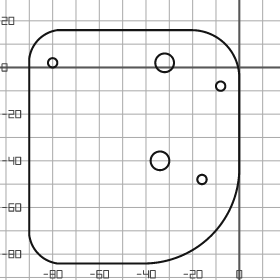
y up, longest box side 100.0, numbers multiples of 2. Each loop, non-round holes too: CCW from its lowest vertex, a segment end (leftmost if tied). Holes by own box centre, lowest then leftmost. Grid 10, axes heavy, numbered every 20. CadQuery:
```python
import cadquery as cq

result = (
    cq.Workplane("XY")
    .moveTo(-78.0, -84.0)
    .lineTo(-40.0, -84.0)
    .threePointArc((-12.0, -72.0), (0.0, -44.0))
    .lineTo(0.0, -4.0)
    .threePointArc((-6.0, 10.0), (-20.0, 16.0))
    .lineTo(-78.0, 16.0)
    .threePointArc((-86.0, 12.0), (-90.0, 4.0))
    .lineTo(-90.0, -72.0)
    .threePointArc((-86.0, -80.0), (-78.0, -84.0))
    .close()
    .moveTo(-16.0, -48.0)
    .circle(2.0)
    .moveTo(-34.0, -40.0)
    .circle(4.0)
    .moveTo(-8.0, -8.0)
    .circle(2.0)
    .moveTo(-80.0, 2.0)
    .circle(2.0)
    .moveTo(-32.0, 2.0)
    .circle(4.0)
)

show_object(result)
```